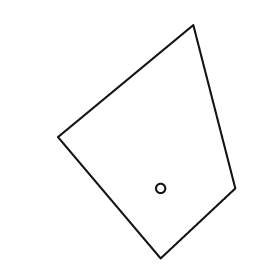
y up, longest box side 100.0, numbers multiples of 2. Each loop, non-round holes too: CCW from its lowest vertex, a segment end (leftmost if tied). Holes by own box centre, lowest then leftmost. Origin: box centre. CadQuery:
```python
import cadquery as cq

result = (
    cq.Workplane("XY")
    .moveTo(6.0, -50.0)
    .lineTo(38.0, -20.0)
    .lineTo(20.0, 50.0)
    .lineTo(-38.0, 2.0)
    .close()
    .moveTo(6.0, -20.0)
    .circle(2.0)
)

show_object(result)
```